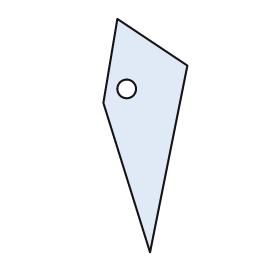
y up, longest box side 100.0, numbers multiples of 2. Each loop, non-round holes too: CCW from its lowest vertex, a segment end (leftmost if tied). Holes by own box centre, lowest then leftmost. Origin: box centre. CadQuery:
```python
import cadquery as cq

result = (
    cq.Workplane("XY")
    .moveTo(2.0, -50.0)
    .lineTo(18.0, 30.0)
    .lineTo(-12.0, 50.0)
    .lineTo(-18.0, 14.0)
    .close()
    .moveTo(-8.0, 20.0)
    .circle(4.0)
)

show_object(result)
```